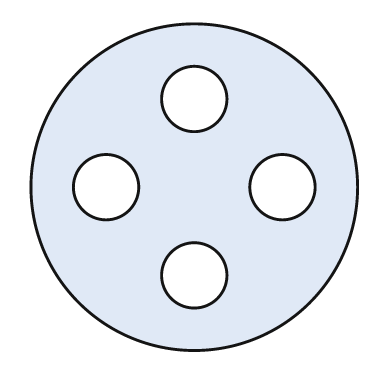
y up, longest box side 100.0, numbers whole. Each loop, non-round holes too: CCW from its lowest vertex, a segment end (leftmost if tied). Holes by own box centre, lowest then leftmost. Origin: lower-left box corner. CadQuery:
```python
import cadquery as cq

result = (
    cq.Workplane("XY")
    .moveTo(50.0, 50.0)
    .circle(50.0)
    .moveTo(50.0, 23.0)
    .circle(10.0)
    .moveTo(23.0, 50.0)
    .circle(10.0)
    .moveTo(77.0, 50.0)
    .circle(10.0)
    .moveTo(50.0, 77.0)
    .circle(10.0)
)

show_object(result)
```